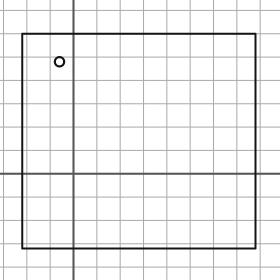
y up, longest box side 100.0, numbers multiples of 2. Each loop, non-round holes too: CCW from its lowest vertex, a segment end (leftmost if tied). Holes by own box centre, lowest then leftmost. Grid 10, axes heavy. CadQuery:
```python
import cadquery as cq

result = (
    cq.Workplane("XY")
    .moveTo(-22.0, -32.0)
    .lineTo(78.0, -32.0)
    .lineTo(78.0, 60.0)
    .lineTo(-22.0, 60.0)
    .close()
    .moveTo(-6.0, 48.0)
    .circle(2.0)
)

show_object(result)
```